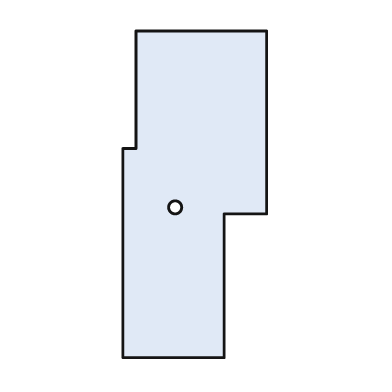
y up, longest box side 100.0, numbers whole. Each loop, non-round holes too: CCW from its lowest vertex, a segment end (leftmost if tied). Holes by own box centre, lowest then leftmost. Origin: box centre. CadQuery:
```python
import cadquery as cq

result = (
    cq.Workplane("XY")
    .moveTo(-22.0, -50.0)
    .lineTo(9.0, -50.0)
    .lineTo(9.0, -6.0)
    .lineTo(22.0, -6.0)
    .lineTo(22.0, 50.0)
    .lineTo(-18.0, 50.0)
    .lineTo(-18.0, 14.0)
    .lineTo(-22.0, 14.0)
    .close()
    .moveTo(-6.0, -4.0)
    .circle(2.0)
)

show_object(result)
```